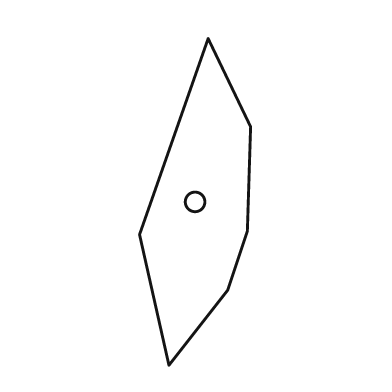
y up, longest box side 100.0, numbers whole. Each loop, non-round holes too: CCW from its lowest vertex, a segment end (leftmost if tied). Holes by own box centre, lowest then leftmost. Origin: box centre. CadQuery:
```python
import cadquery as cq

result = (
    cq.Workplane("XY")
    .moveTo(-8.0, -50.0)
    .lineTo(10.0, -27.0)
    .lineTo(16.0, -9.0)
    .lineTo(17.0, 23.0)
    .lineTo(4.0, 50.0)
    .lineTo(-17.0, -10.0)
    .close()
    .moveTo(0.0, 0.0)
    .circle(3.0)
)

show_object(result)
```